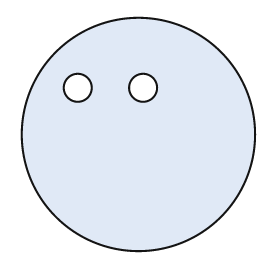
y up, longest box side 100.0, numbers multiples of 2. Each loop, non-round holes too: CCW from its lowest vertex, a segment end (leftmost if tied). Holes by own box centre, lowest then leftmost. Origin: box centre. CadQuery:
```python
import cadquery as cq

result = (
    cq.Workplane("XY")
    .moveTo(0.0, 0.0)
    .circle(50.0)
    .moveTo(-26.0, 20.0)
    .circle(6.0)
    .moveTo(2.0, 20.0)
    .circle(6.0)
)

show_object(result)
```